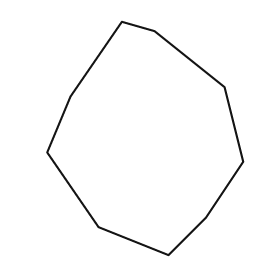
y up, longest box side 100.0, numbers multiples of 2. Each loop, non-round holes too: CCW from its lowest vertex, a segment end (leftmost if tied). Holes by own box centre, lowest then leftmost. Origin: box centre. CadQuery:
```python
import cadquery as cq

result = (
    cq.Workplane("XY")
    .moveTo(10.0, -50.0)
    .lineTo(26.0, -34.0)
    .lineTo(42.0, -10.0)
    .lineTo(34.0, 22.0)
    .lineTo(4.0, 46.0)
    .lineTo(-10.0, 50.0)
    .lineTo(-32.0, 18.0)
    .lineTo(-42.0, -6.0)
    .lineTo(-20.0, -38.0)
    .close()
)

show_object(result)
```